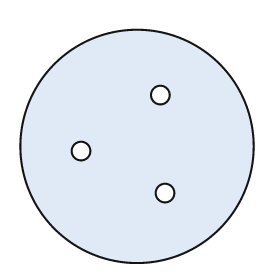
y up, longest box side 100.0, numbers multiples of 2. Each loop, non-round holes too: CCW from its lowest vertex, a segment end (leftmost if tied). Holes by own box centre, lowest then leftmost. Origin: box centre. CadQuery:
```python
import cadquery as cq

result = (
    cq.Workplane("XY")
    .moveTo(0.0, 0.0)
    .circle(50.0)
    .moveTo(12.0, -20.0)
    .circle(4.0)
    .moveTo(-24.0, -2.0)
    .circle(4.0)
    .moveTo(10.0, 22.0)
    .circle(4.0)
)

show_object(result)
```